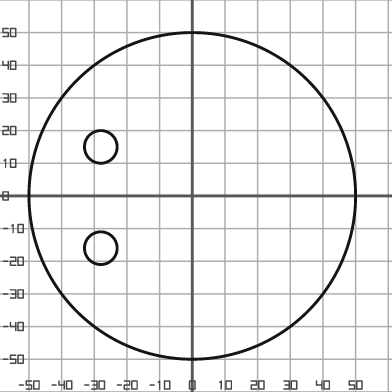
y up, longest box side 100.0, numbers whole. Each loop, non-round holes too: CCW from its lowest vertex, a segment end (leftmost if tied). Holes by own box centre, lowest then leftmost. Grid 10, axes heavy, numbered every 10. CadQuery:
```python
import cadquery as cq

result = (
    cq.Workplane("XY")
    .moveTo(0.0, 0.0)
    .circle(50.0)
    .moveTo(-28.0, -16.0)
    .circle(5.0)
    .moveTo(-28.0, 15.0)
    .circle(5.0)
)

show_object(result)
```